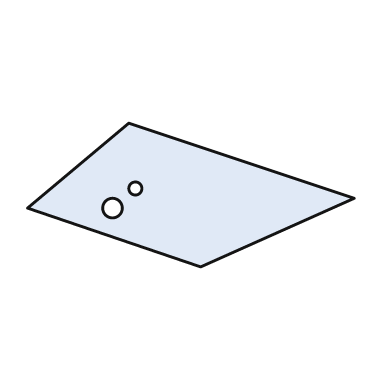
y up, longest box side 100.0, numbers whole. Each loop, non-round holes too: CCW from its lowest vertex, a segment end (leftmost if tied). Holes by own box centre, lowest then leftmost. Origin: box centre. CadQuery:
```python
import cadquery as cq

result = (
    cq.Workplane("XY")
    .moveTo(3.0, -22.0)
    .lineTo(50.0, -1.0)
    .lineTo(-19.0, 22.0)
    .lineTo(-50.0, -4.0)
    .close()
    .moveTo(-24.0, -4.0)
    .circle(3.0)
    .moveTo(-17.0, 2.0)
    .circle(2.0)
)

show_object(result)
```